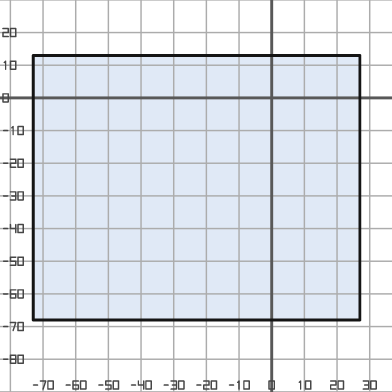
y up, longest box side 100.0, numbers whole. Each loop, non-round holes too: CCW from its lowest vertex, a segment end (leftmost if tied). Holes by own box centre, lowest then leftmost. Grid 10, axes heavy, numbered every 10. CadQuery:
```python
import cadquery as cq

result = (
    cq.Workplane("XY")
    .moveTo(-73.0, -68.0)
    .lineTo(27.0, -68.0)
    .lineTo(27.0, 13.0)
    .lineTo(-73.0, 13.0)
    .close()
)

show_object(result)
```